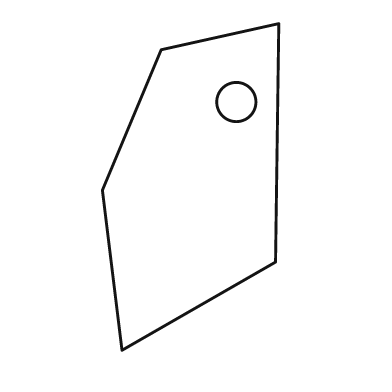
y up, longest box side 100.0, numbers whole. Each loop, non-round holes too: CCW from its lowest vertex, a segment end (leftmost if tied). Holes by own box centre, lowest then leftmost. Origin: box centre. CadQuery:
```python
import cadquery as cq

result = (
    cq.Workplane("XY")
    .moveTo(-21.0, -50.0)
    .lineTo(26.0, -23.0)
    .lineTo(27.0, 50.0)
    .lineTo(-9.0, 42.0)
    .lineTo(-27.0, -1.0)
    .close()
    .moveTo(14.0, 26.0)
    .circle(6.0)
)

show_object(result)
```